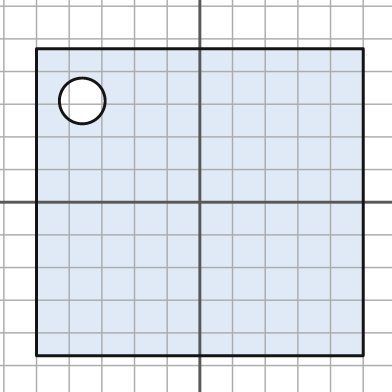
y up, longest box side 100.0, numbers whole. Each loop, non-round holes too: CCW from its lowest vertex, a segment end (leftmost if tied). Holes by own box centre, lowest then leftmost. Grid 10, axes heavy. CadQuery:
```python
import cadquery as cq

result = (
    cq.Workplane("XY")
    .moveTo(-50.0, -47.0)
    .lineTo(50.0, -47.0)
    .lineTo(50.0, 47.0)
    .lineTo(-50.0, 47.0)
    .close()
    .moveTo(-36.0, 31.0)
    .circle(7.0)
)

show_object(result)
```